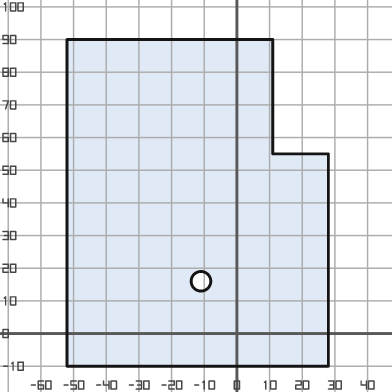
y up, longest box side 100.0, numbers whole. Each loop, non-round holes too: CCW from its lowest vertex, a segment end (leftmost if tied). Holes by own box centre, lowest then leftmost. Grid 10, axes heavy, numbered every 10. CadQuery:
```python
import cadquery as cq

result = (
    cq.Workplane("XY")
    .moveTo(-52.0, -10.0)
    .lineTo(28.0, -10.0)
    .lineTo(28.0, 55.0)
    .lineTo(11.0, 55.0)
    .lineTo(11.0, 90.0)
    .lineTo(-52.0, 90.0)
    .close()
    .moveTo(-11.0, 16.0)
    .circle(3.0)
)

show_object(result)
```